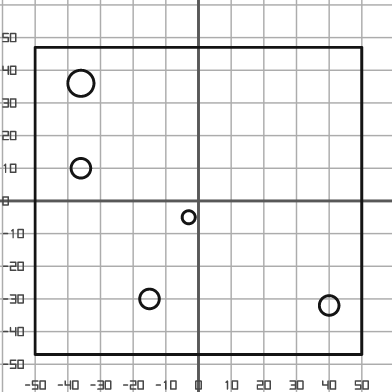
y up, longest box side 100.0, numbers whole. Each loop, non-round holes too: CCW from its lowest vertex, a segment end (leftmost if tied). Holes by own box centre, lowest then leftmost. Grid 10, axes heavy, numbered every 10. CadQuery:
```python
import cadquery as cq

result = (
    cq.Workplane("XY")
    .moveTo(-50.0, -47.0)
    .lineTo(50.0, -47.0)
    .lineTo(50.0, 47.0)
    .lineTo(-50.0, 47.0)
    .close()
    .moveTo(40.0, -32.0)
    .circle(3.0)
    .moveTo(-15.0, -30.0)
    .circle(3.0)
    .moveTo(-3.0, -5.0)
    .circle(2.0)
    .moveTo(-36.0, 10.0)
    .circle(3.0)
    .moveTo(-36.0, 36.0)
    .circle(4.0)
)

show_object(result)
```